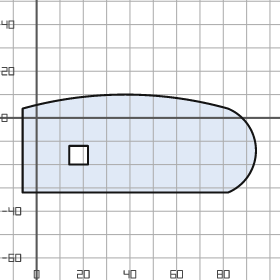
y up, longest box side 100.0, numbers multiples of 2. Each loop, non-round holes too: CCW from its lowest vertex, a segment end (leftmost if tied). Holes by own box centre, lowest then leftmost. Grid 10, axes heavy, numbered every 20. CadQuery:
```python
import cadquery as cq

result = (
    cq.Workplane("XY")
    .moveTo(-6.0, -32.0)
    .lineTo(82.0, -32.0)
    .threePointArc((94.0, -14.0), (82.0, 4.0))
    .threePointArc((38.0, 10.0), (-6.0, 4.0))
    .close()
    .moveTo(14.0, -20.0)
    .lineTo(22.0, -20.0)
    .lineTo(22.0, -12.0)
    .lineTo(14.0, -12.0)
    .close()
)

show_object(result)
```